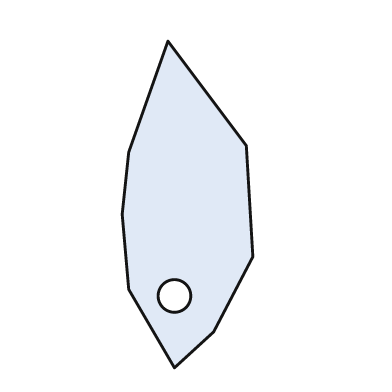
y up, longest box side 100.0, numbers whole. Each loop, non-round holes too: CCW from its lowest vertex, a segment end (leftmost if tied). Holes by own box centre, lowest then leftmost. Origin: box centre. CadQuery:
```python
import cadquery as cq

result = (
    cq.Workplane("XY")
    .moveTo(-4.0, -50.0)
    .lineTo(8.0, -39.0)
    .lineTo(20.0, -16.0)
    .lineTo(18.0, 18.0)
    .lineTo(-6.0, 50.0)
    .lineTo(-18.0, 16.0)
    .lineTo(-20.0, -3.0)
    .lineTo(-18.0, -26.0)
    .close()
    .moveTo(-4.0, -28.0)
    .circle(5.0)
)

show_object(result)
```